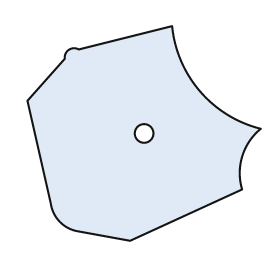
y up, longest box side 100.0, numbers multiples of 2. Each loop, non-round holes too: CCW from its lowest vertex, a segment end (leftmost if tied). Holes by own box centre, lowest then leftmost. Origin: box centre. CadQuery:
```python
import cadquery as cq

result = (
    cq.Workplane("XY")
    .moveTo(-6.0, -46.0)
    .lineTo(42.0, -24.0)
    .threePointArc((42.0, -10.0), (50.0, 2.0))
    .threePointArc((24.0, 18.0), (12.0, 46.0))
    .lineTo(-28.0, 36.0)
    .threePointArc((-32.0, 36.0), (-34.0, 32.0))
    .lineTo(-50.0, 14.0)
    .lineTo(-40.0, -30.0)
    .threePointArc((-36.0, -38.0), (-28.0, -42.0))
    .close()
    .moveTo(0.0, 0.0)
    .circle(4.0)
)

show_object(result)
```